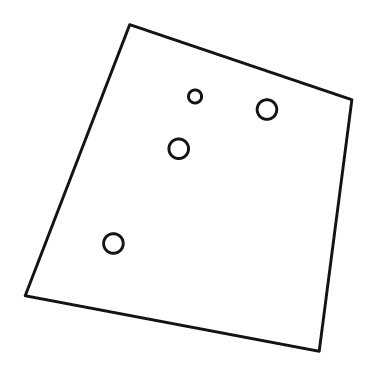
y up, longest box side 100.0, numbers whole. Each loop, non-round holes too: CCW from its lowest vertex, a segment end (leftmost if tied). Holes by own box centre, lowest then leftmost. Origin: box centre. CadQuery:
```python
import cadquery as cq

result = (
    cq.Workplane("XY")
    .moveTo(40.0, -50.0)
    .lineTo(50.0, 27.0)
    .lineTo(-18.0, 50.0)
    .lineTo(-50.0, -33.0)
    .close()
    .moveTo(-23.0, -17.0)
    .circle(3.0)
    .moveTo(-3.0, 12.0)
    .circle(3.0)
    .moveTo(24.0, 24.0)
    .circle(3.0)
    .moveTo(2.0, 28.0)
    .circle(2.0)
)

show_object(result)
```